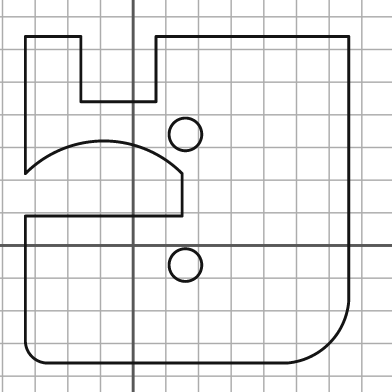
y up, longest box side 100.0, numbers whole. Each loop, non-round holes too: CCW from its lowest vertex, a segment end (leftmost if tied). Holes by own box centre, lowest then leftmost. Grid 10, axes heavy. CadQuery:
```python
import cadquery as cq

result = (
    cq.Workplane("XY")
    .moveTo(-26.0, -36.0)
    .lineTo(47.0, -36.0)
    .threePointArc((60.0, -30.0), (66.0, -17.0))
    .lineTo(66.0, 64.0)
    .lineTo(7.0, 64.0)
    .lineTo(7.0, 44.0)
    .lineTo(-16.0, 44.0)
    .lineTo(-16.0, 64.0)
    .lineTo(-33.0, 64.0)
    .lineTo(-33.0, 22.0)
    .threePointArc((-9.0, 32.0), (15.0, 22.0))
    .lineTo(15.0, 9.0)
    .lineTo(-33.0, 9.0)
    .lineTo(-33.0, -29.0)
    .threePointArc((-31.0, -34.0), (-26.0, -36.0))
    .close()
    .moveTo(16.0, -6.0)
    .circle(5.0)
    .moveTo(16.0, 34.0)
    .circle(5.0)
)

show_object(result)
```